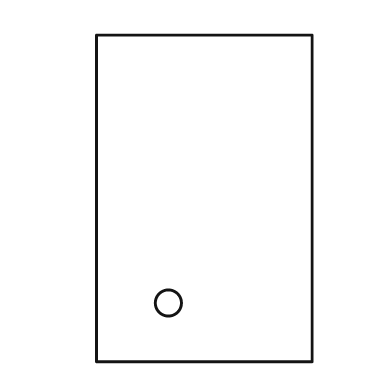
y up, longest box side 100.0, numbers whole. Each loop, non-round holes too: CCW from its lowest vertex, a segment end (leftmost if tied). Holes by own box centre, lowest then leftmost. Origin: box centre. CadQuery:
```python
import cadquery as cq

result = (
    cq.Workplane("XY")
    .moveTo(-33.0, -50.0)
    .lineTo(33.0, -50.0)
    .lineTo(33.0, 50.0)
    .lineTo(-33.0, 50.0)
    .close()
    .moveTo(-11.0, -32.0)
    .circle(4.0)
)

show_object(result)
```